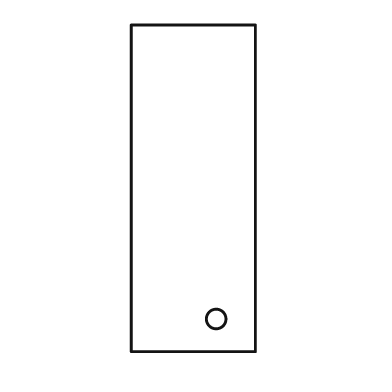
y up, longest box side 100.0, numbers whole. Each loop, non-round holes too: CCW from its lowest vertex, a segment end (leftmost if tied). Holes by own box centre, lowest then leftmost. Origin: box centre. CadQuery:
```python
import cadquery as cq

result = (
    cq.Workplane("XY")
    .moveTo(-19.0, -50.0)
    .lineTo(19.0, -50.0)
    .lineTo(19.0, 50.0)
    .lineTo(-19.0, 50.0)
    .close()
    .moveTo(7.0, -40.0)
    .circle(3.0)
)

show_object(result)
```